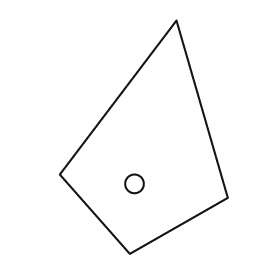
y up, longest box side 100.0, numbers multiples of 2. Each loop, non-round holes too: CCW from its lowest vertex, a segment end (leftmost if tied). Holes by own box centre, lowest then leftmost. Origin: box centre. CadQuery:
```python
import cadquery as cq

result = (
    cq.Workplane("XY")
    .moveTo(-6.0, -50.0)
    .lineTo(36.0, -26.0)
    .lineTo(14.0, 50.0)
    .lineTo(-36.0, -16.0)
    .close()
    .moveTo(-4.0, -20.0)
    .circle(4.0)
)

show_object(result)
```